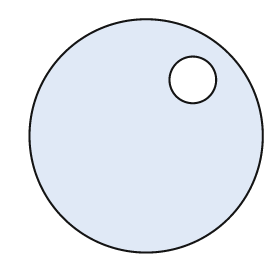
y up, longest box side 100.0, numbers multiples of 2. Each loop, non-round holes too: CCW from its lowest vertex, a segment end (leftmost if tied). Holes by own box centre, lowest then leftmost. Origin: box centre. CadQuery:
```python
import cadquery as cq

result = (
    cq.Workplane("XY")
    .moveTo(0.0, 0.0)
    .circle(50.0)
    .moveTo(20.0, 24.0)
    .circle(10.0)
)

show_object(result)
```